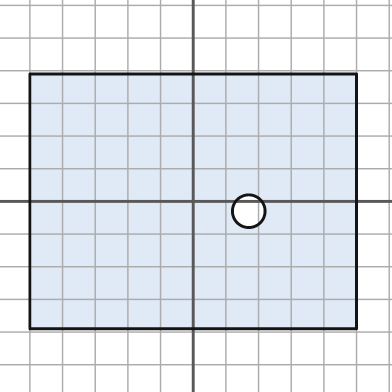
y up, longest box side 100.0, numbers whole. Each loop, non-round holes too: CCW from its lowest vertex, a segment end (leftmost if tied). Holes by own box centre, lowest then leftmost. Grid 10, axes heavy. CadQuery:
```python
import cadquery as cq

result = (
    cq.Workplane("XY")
    .moveTo(-50.0, -39.0)
    .lineTo(50.0, -39.0)
    .lineTo(50.0, 39.0)
    .lineTo(-50.0, 39.0)
    .close()
    .moveTo(17.0, -3.0)
    .circle(5.0)
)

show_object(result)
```